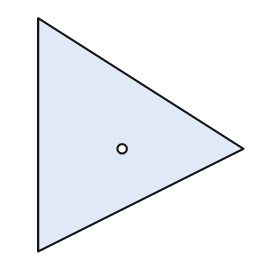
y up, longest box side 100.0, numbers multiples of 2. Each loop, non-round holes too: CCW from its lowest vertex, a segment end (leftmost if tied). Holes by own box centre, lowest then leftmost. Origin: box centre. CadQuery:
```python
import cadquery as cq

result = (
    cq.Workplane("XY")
    .moveTo(-44.0, -50.0)
    .lineTo(44.0, -6.0)
    .lineTo(-44.0, 50.0)
    .close()
    .moveTo(-8.0, -6.0)
    .circle(2.0)
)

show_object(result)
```